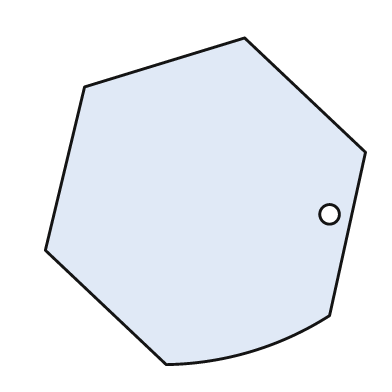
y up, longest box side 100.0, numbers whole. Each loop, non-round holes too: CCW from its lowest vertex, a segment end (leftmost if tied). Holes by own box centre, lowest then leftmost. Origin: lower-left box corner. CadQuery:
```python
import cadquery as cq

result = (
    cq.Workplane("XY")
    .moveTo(37.0, 0.0)
    .threePointArc((63.0, 4.0), (87.0, 15.0))
    .lineTo(98.0, 65.0)
    .lineTo(61.0, 100.0)
    .lineTo(12.0, 85.0)
    .lineTo(0.0, 35.0)
    .close()
    .moveTo(87.0, 46.0)
    .circle(3.0)
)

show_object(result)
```